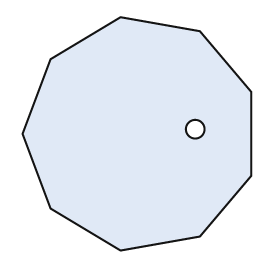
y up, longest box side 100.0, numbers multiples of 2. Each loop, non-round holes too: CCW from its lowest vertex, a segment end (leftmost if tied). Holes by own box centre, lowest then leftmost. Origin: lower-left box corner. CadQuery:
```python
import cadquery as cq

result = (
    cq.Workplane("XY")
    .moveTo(42.0, 0.0)
    .lineTo(76.0, 6.0)
    .lineTo(98.0, 32.0)
    .lineTo(98.0, 68.0)
    .lineTo(76.0, 94.0)
    .lineTo(42.0, 100.0)
    .lineTo(12.0, 82.0)
    .lineTo(0.0, 50.0)
    .lineTo(12.0, 18.0)
    .close()
    .moveTo(74.0, 52.0)
    .circle(4.0)
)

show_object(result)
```